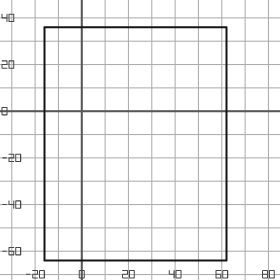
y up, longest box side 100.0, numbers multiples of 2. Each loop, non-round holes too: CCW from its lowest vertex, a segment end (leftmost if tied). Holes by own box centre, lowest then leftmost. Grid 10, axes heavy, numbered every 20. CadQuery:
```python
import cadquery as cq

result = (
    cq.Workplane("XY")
    .moveTo(-16.0, -64.0)
    .lineTo(62.0, -64.0)
    .lineTo(62.0, 36.0)
    .lineTo(-16.0, 36.0)
    .close()
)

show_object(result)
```